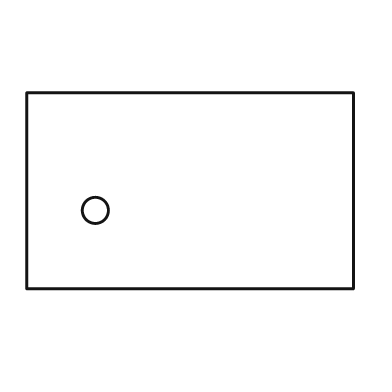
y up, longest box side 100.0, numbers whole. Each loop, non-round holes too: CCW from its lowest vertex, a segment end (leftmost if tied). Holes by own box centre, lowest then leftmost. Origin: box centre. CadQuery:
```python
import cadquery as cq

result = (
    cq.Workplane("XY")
    .moveTo(-50.0, -30.0)
    .lineTo(50.0, -30.0)
    .lineTo(50.0, 30.0)
    .lineTo(-50.0, 30.0)
    .close()
    .moveTo(-29.0, -6.0)
    .circle(4.0)
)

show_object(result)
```